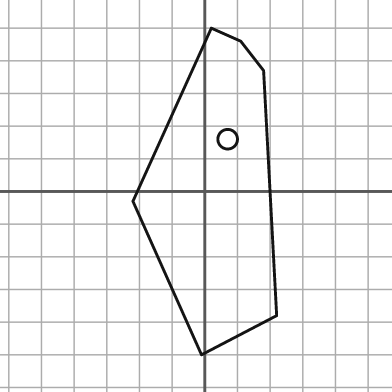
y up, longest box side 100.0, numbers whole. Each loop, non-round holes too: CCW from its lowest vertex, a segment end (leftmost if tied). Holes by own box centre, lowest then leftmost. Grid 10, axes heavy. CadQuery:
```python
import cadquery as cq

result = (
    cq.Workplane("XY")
    .moveTo(-1.0, -50.0)
    .lineTo(22.0, -38.0)
    .lineTo(18.0, 37.0)
    .lineTo(11.0, 46.0)
    .lineTo(2.0, 50.0)
    .lineTo(-22.0, -3.0)
    .close()
    .moveTo(7.0, 16.0)
    .circle(3.0)
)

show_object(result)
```